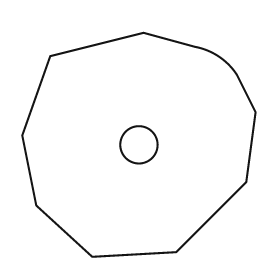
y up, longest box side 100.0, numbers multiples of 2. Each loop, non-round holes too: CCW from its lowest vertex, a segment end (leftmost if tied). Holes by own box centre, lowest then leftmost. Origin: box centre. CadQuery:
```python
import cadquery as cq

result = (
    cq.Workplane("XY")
    .moveTo(-20.0, -48.0)
    .lineTo(16.0, -46.0)
    .lineTo(46.0, -16.0)
    .lineTo(50.0, 14.0)
    .lineTo(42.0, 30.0)
    .threePointArc((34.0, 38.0), (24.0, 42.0))
    .lineTo(2.0, 48.0)
    .lineTo(-38.0, 38.0)
    .lineTo(-50.0, 4.0)
    .lineTo(-44.0, -26.0)
    .close()
    .moveTo(0.0, 0.0)
    .circle(8.0)
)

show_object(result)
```